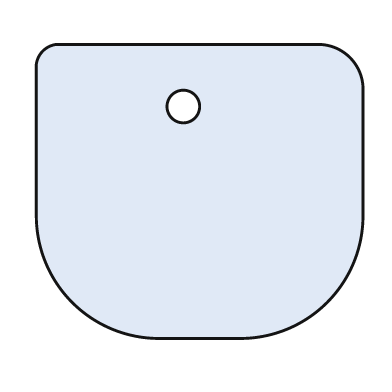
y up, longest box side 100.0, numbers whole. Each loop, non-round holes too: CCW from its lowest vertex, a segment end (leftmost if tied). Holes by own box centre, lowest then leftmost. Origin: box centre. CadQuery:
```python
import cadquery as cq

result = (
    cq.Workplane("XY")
    .moveTo(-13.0, -45.0)
    .lineTo(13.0, -45.0)
    .threePointArc((39.0, -34.0), (50.0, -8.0))
    .lineTo(50.0, 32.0)
    .threePointArc((46.0, 41.0), (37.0, 45.0))
    .lineTo(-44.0, 45.0)
    .threePointArc((-48.0, 43.0), (-50.0, 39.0))
    .lineTo(-50.0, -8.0)
    .threePointArc((-39.0, -34.0), (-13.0, -45.0))
    .close()
    .moveTo(-5.0, 26.0)
    .circle(5.0)
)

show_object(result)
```